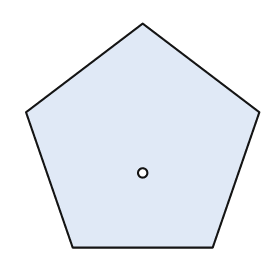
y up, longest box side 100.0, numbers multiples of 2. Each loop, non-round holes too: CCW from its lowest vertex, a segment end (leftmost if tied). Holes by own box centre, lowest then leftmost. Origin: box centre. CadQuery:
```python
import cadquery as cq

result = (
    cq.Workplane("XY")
    .moveTo(-30.0, -48.0)
    .lineTo(30.0, -48.0)
    .lineTo(50.0, 10.0)
    .lineTo(0.0, 48.0)
    .lineTo(-50.0, 10.0)
    .close()
    .moveTo(0.0, -16.0)
    .circle(2.0)
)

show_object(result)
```